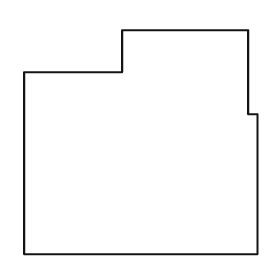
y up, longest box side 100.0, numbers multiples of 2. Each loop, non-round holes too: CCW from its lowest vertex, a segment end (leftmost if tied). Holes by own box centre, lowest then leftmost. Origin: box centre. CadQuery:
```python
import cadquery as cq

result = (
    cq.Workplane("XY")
    .moveTo(-50.0, -48.0)
    .lineTo(50.0, -48.0)
    .lineTo(50.0, 12.0)
    .lineTo(46.0, 12.0)
    .lineTo(46.0, 48.0)
    .lineTo(-8.0, 48.0)
    .lineTo(-8.0, 30.0)
    .lineTo(-50.0, 30.0)
    .close()
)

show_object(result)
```